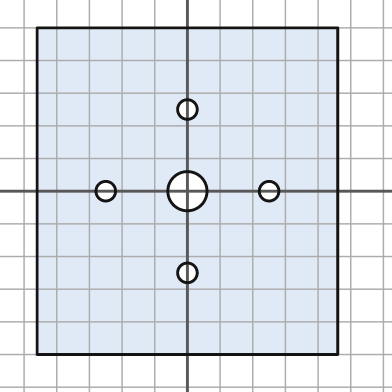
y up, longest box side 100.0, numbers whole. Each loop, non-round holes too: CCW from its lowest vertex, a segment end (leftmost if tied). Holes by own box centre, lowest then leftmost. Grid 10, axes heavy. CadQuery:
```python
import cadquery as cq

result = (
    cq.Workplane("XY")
    .moveTo(-46.0, -50.0)
    .lineTo(46.0, -50.0)
    .lineTo(46.0, 50.0)
    .lineTo(-46.0, 50.0)
    .close()
    .moveTo(0.0, -25.0)
    .circle(3.0)
    .moveTo(-25.0, 0.0)
    .circle(3.0)
    .moveTo(0.0, 0.0)
    .circle(6.0)
    .moveTo(25.0, 0.0)
    .circle(3.0)
    .moveTo(0.0, 25.0)
    .circle(3.0)
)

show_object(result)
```